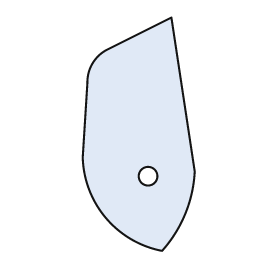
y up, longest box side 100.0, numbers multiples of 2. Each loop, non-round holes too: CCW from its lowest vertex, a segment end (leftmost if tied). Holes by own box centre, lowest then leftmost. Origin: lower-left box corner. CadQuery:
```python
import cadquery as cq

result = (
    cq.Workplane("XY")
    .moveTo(34.0, 0.0)
    .threePointArc((44.0, 16.0), (48.0, 34.0))
    .lineTo(38.0, 100.0)
    .lineTo(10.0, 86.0)
    .threePointArc((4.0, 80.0), (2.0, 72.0))
    .lineTo(0.0, 40.0)
    .threePointArc((10.0, 14.0), (34.0, 0.0))
    .close()
    .moveTo(28.0, 32.0)
    .circle(4.0)
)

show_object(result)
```